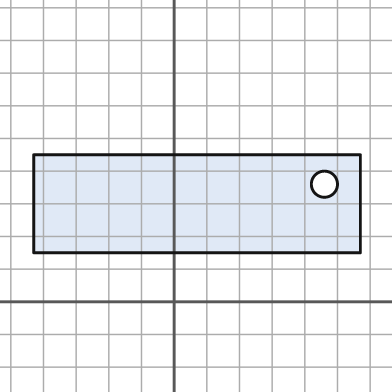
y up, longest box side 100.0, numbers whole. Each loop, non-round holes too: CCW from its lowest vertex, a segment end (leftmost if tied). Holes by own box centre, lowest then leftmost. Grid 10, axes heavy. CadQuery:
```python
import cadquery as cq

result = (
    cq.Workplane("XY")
    .moveTo(-43.0, 15.0)
    .lineTo(57.0, 15.0)
    .lineTo(57.0, 45.0)
    .lineTo(-43.0, 45.0)
    .close()
    .moveTo(46.0, 36.0)
    .circle(4.0)
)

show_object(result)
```